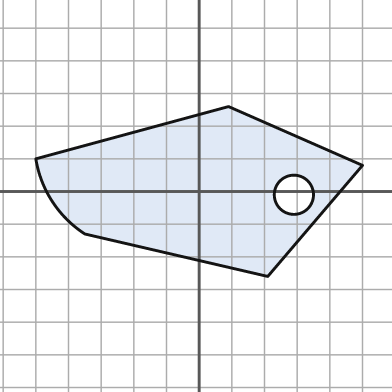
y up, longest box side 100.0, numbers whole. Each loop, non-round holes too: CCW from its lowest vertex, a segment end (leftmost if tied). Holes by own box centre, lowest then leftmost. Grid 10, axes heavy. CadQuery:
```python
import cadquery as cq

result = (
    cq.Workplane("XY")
    .moveTo(21.0, -26.0)
    .lineTo(50.0, 8.0)
    .lineTo(9.0, 26.0)
    .lineTo(-50.0, 10.0)
    .threePointArc((-45.0, -3.0), (-35.0, -13.0))
    .close()
    .moveTo(29.0, -1.0)
    .circle(6.0)
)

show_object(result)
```